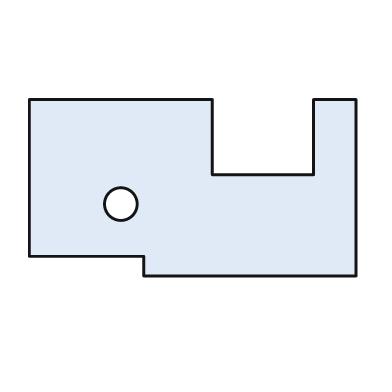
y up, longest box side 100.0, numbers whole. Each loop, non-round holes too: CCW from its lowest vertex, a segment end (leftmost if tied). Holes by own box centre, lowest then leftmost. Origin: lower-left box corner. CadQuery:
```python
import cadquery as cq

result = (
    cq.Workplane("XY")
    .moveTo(35.0, 0.0)
    .lineTo(100.0, 0.0)
    .lineTo(100.0, 54.0)
    .lineTo(87.0, 54.0)
    .lineTo(87.0, 31.0)
    .lineTo(56.0, 31.0)
    .lineTo(56.0, 54.0)
    .lineTo(0.0, 54.0)
    .lineTo(0.0, 6.0)
    .lineTo(35.0, 6.0)
    .close()
    .moveTo(28.0, 22.0)
    .circle(5.0)
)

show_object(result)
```